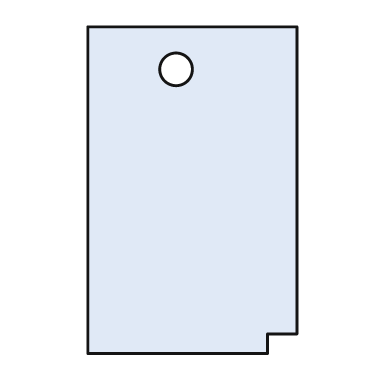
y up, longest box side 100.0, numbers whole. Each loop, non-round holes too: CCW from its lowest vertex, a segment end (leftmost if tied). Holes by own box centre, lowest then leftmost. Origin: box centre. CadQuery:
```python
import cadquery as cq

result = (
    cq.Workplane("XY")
    .moveTo(-32.0, -50.0)
    .lineTo(23.0, -50.0)
    .lineTo(23.0, -44.0)
    .lineTo(32.0, -44.0)
    .lineTo(32.0, 50.0)
    .lineTo(-32.0, 50.0)
    .close()
    .moveTo(-5.0, 37.0)
    .circle(5.0)
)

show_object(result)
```